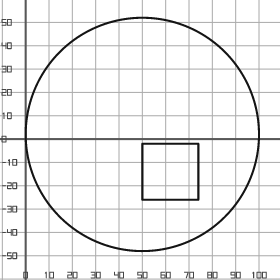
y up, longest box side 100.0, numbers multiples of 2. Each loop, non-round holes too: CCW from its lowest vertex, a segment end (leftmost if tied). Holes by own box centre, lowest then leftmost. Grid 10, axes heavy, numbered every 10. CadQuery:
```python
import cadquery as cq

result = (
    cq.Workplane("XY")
    .moveTo(50.0, 2.0)
    .circle(50.0)
    .moveTo(50.0, -26.0)
    .lineTo(74.0, -26.0)
    .lineTo(74.0, -2.0)
    .lineTo(50.0, -2.0)
    .close()
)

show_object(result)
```